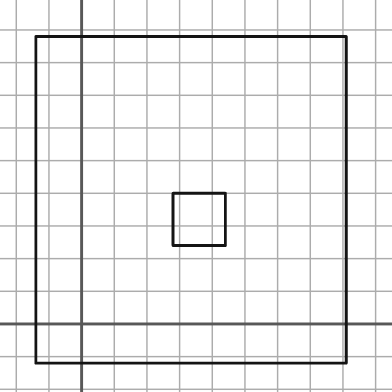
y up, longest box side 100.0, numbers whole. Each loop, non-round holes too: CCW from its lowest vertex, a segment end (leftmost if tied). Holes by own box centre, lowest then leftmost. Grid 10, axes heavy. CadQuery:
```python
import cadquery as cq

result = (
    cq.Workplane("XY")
    .moveTo(-14.0, -12.0)
    .lineTo(81.0, -12.0)
    .lineTo(81.0, 88.0)
    .lineTo(-14.0, 88.0)
    .close()
    .moveTo(28.0, 24.0)
    .lineTo(44.0, 24.0)
    .lineTo(44.0, 40.0)
    .lineTo(28.0, 40.0)
    .close()
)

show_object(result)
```